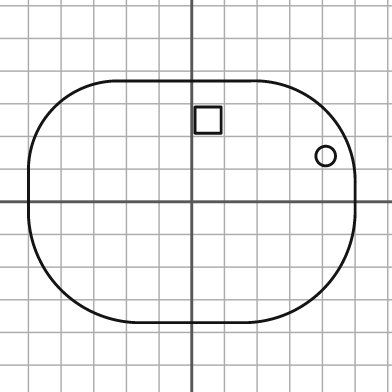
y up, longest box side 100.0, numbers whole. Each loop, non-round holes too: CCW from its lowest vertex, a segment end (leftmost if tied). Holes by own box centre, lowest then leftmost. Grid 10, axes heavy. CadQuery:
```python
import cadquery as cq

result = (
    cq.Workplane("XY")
    .moveTo(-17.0, -37.0)
    .lineTo(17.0, -37.0)
    .threePointArc((40.0, -27.0), (50.0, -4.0))
    .lineTo(50.0, 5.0)
    .threePointArc((41.0, 28.0), (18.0, 37.0))
    .lineTo(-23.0, 37.0)
    .threePointArc((-42.0, 29.0), (-50.0, 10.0))
    .lineTo(-50.0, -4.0)
    .threePointArc((-40.0, -27.0), (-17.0, -37.0))
    .close()
    .moveTo(41.0, 14.0)
    .circle(3.0)
    .moveTo(1.0, 21.0)
    .lineTo(9.0, 21.0)
    .lineTo(9.0, 29.0)
    .lineTo(1.0, 29.0)
    .close()
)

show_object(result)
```